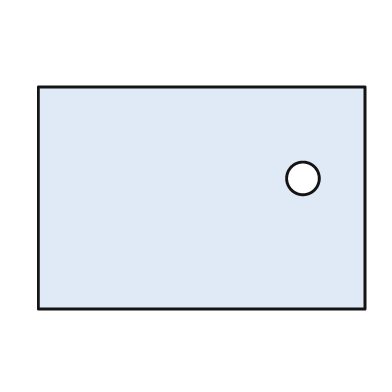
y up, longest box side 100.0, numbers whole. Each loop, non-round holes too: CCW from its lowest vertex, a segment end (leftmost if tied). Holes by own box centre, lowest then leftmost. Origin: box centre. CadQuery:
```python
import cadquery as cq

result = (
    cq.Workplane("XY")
    .moveTo(-50.0, -34.0)
    .lineTo(50.0, -34.0)
    .lineTo(50.0, 34.0)
    .lineTo(-50.0, 34.0)
    .close()
    .moveTo(31.0, 6.0)
    .circle(5.0)
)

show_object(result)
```